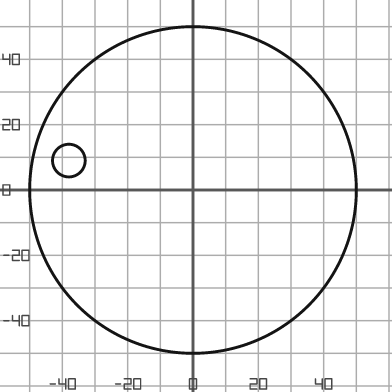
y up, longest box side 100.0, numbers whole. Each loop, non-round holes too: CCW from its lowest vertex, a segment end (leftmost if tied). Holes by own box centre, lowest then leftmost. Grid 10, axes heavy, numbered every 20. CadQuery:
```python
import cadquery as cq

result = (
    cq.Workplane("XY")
    .moveTo(0.0, 0.0)
    .circle(50.0)
    .moveTo(-38.0, 9.0)
    .circle(5.0)
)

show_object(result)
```